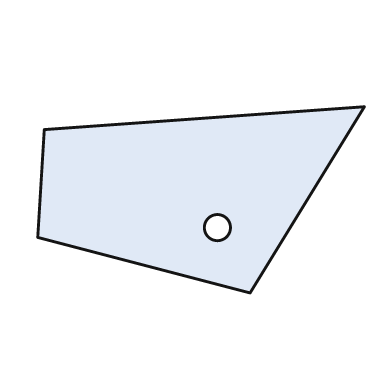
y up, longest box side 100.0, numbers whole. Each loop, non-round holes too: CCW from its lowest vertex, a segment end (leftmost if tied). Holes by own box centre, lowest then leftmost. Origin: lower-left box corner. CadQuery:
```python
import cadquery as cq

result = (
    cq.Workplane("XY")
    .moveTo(65.0, 0.0)
    .lineTo(100.0, 57.0)
    .lineTo(2.0, 50.0)
    .lineTo(0.0, 17.0)
    .close()
    .moveTo(55.0, 20.0)
    .circle(4.0)
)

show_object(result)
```